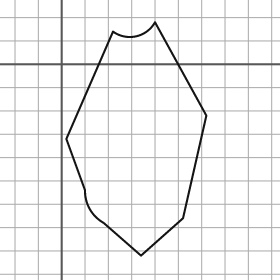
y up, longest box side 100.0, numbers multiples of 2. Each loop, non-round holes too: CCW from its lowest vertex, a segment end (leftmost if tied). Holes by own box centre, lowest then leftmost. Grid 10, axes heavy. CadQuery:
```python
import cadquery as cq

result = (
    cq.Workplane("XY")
    .moveTo(34.0, -82.0)
    .lineTo(52.0, -66.0)
    .lineTo(62.0, -22.0)
    .lineTo(40.0, 18.0)
    .threePointArc((32.0, 12.0), (22.0, 14.0))
    .lineTo(2.0, -32.0)
    .lineTo(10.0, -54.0)
    .threePointArc((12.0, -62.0), (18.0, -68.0))
    .close()
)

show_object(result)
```